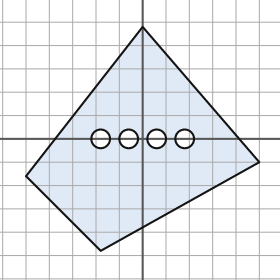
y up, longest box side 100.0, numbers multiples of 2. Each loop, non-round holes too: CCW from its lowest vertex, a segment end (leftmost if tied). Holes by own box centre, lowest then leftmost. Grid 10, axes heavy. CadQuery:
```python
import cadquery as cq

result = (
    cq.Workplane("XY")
    .moveTo(-18.0, -48.0)
    .lineTo(50.0, -10.0)
    .lineTo(0.0, 48.0)
    .lineTo(-50.0, -16.0)
    .close()
    .moveTo(-18.0, 0.0)
    .circle(4.0)
    .moveTo(-6.0, 0.0)
    .circle(4.0)
    .moveTo(6.0, 0.0)
    .circle(4.0)
    .moveTo(18.0, 0.0)
    .circle(4.0)
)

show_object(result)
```